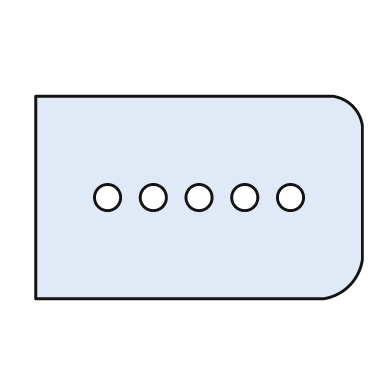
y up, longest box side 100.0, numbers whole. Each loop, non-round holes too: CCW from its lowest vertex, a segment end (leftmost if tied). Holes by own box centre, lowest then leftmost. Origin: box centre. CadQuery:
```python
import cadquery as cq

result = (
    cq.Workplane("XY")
    .moveTo(-50.0, -31.0)
    .lineTo(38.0, -31.0)
    .threePointArc((46.0, -27.0), (50.0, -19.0))
    .lineTo(50.0, 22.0)
    .threePointArc((47.0, 28.0), (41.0, 31.0))
    .lineTo(-50.0, 31.0)
    .close()
    .moveTo(-28.0, 0.0)
    .circle(4.0)
    .moveTo(-14.0, 0.0)
    .circle(4.0)
    .moveTo(0.0, 0.0)
    .circle(4.0)
    .moveTo(14.0, 0.0)
    .circle(4.0)
    .moveTo(28.0, 0.0)
    .circle(4.0)
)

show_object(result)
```